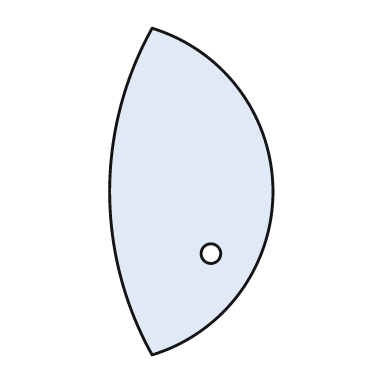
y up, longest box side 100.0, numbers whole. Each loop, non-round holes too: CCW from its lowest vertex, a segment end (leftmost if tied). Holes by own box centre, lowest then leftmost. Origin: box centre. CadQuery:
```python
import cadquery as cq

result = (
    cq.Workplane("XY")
    .moveTo(-12.0, -50.0)
    .threePointArc((25.0, 0.0), (-12.0, 50.0))
    .threePointArc((-25.0, 0.0), (-12.0, -50.0))
    .close()
    .moveTo(6.0, -19.0)
    .circle(3.0)
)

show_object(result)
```